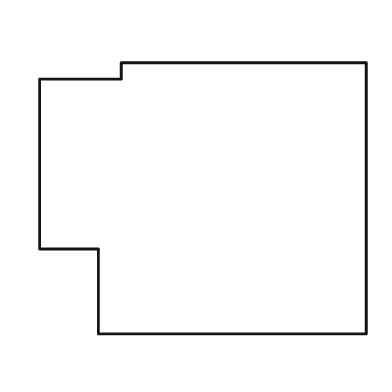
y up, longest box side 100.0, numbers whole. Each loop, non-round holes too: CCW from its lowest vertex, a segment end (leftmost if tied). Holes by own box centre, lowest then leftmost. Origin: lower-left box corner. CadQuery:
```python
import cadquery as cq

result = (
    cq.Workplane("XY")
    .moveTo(18.0, 0.0)
    .lineTo(100.0, 0.0)
    .lineTo(100.0, 83.0)
    .lineTo(25.0, 83.0)
    .lineTo(25.0, 78.0)
    .lineTo(0.0, 78.0)
    .lineTo(0.0, 26.0)
    .lineTo(18.0, 26.0)
    .close()
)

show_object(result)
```